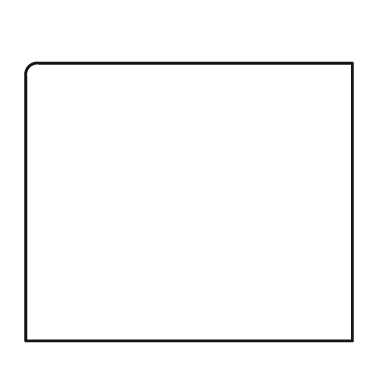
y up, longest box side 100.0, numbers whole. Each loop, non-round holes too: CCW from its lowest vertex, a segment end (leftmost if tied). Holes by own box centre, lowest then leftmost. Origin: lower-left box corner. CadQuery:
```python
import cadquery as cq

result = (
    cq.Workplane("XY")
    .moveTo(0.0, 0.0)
    .lineTo(100.0, 0.0)
    .lineTo(100.0, 85.0)
    .lineTo(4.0, 85.0)
    .threePointArc((1.0, 84.0), (0.0, 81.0))
    .close()
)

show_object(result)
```